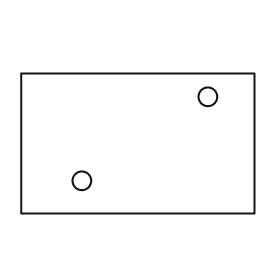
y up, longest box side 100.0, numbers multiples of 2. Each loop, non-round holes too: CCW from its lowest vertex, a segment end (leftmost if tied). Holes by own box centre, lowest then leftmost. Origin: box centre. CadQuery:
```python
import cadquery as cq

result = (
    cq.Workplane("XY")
    .moveTo(-50.0, -30.0)
    .lineTo(50.0, -30.0)
    .lineTo(50.0, 30.0)
    .lineTo(-50.0, 30.0)
    .close()
    .moveTo(-24.0, -16.0)
    .circle(4.0)
    .moveTo(30.0, 20.0)
    .circle(4.0)
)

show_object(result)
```